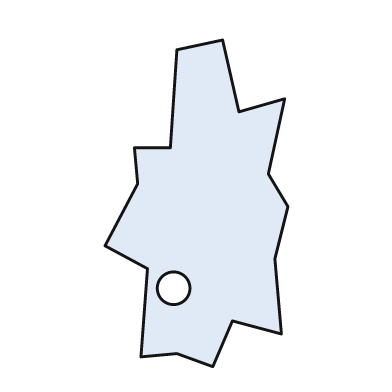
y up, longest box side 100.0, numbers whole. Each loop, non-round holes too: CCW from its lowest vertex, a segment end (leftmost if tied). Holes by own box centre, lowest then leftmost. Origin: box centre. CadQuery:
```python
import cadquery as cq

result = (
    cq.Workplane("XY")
    .moveTo(5.0, -50.0)
    .lineTo(11.0, -36.0)
    .lineTo(26.0, -40.0)
    .lineTo(24.0, -17.0)
    .lineTo(28.0, -1.0)
    .lineTo(22.0, 9.0)
    .lineTo(27.0, 32.0)
    .lineTo(13.0, 28.0)
    .lineTo(8.0, 50.0)
    .lineTo(-6.0, 47.0)
    .lineTo(-8.0, 17.0)
    .lineTo(-19.0, 17.0)
    .lineTo(-18.0, 6.0)
    .lineTo(-28.0, -13.0)
    .lineTo(-15.0, -20.0)
    .lineTo(-17.0, -47.0)
    .lineTo(-6.0, -46.0)
    .close()
    .moveTo(-7.0, -26.0)
    .circle(5.0)
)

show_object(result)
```